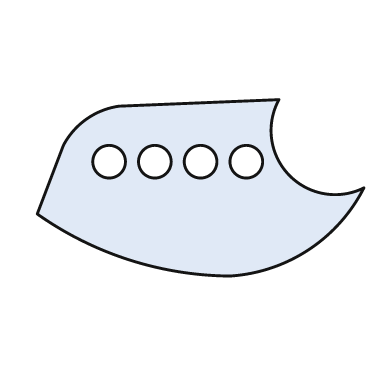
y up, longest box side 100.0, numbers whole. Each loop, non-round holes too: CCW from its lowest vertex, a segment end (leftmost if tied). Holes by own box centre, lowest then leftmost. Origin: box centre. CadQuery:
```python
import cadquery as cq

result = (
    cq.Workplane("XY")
    .moveTo(9.0, -27.0)
    .threePointArc((33.0, -19.0), (50.0, 0.0))
    .threePointArc((27.0, 4.0), (24.0, 27.0))
    .lineTo(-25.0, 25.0)
    .threePointArc((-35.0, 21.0), (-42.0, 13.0))
    .lineTo(-50.0, -8.0)
    .threePointArc((-22.0, -22.0), (9.0, -27.0))
    .close()
    .moveTo(-28.0, 8.0)
    .circle(5.0)
    .moveTo(-14.0, 8.0)
    .circle(5.0)
    .moveTo(0.0, 8.0)
    .circle(5.0)
    .moveTo(14.0, 8.0)
    .circle(5.0)
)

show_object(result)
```